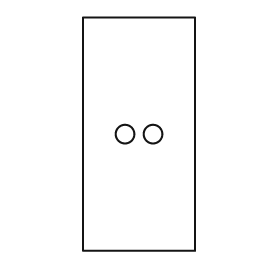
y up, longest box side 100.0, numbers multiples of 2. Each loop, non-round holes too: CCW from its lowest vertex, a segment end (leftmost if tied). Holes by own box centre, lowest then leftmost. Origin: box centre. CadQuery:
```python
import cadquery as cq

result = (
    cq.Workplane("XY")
    .moveTo(-24.0, -50.0)
    .lineTo(24.0, -50.0)
    .lineTo(24.0, 50.0)
    .lineTo(-24.0, 50.0)
    .close()
    .moveTo(-6.0, 0.0)
    .circle(4.0)
    .moveTo(6.0, 0.0)
    .circle(4.0)
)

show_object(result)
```